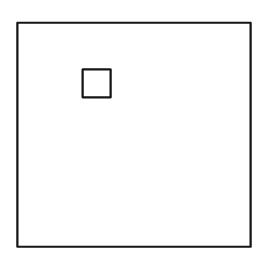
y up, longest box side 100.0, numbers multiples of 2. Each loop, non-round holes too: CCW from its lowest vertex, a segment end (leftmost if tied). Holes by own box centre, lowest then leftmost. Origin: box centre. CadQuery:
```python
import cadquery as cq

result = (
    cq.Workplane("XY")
    .moveTo(-50.0, -48.0)
    .lineTo(50.0, -48.0)
    .lineTo(50.0, 48.0)
    .lineTo(-50.0, 48.0)
    .close()
    .moveTo(-22.0, 16.0)
    .lineTo(-10.0, 16.0)
    .lineTo(-10.0, 28.0)
    .lineTo(-22.0, 28.0)
    .close()
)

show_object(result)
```